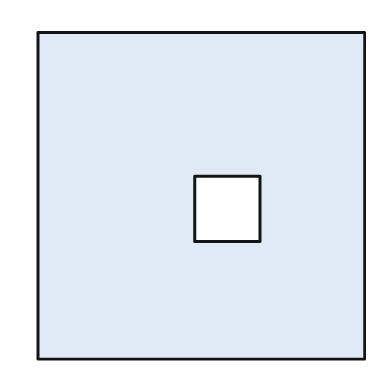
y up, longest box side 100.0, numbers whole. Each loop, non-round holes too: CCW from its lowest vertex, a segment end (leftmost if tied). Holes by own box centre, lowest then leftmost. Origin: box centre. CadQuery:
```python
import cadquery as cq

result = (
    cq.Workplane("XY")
    .moveTo(-50.0, -50.0)
    .lineTo(50.0, -50.0)
    .lineTo(50.0, 50.0)
    .lineTo(-50.0, 50.0)
    .close()
    .moveTo(-2.0, -14.0)
    .lineTo(18.0, -14.0)
    .lineTo(18.0, 6.0)
    .lineTo(-2.0, 6.0)
    .close()
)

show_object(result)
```